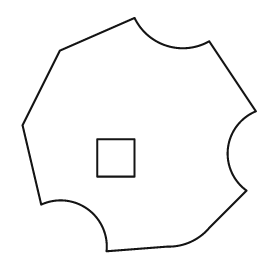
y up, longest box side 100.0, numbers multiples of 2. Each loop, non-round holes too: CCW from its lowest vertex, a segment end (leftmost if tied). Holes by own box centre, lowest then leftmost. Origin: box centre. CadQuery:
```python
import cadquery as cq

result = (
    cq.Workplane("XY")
    .moveTo(-14.0, -50.0)
    .lineTo(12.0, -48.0)
    .threePointArc((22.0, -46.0), (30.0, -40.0))
    .lineTo(46.0, -24.0)
    .threePointArc((38.0, -6.0), (50.0, 10.0))
    .lineTo(30.0, 40.0)
    .threePointArc((12.0, 38.0), (-2.0, 50.0))
    .lineTo(-34.0, 36.0)
    .lineTo(-50.0, 4.0)
    .lineTo(-42.0, -30.0)
    .threePointArc((-22.0, -32.0), (-14.0, -50.0))
    .close()
    .moveTo(-18.0, -18.0)
    .lineTo(-2.0, -18.0)
    .lineTo(-2.0, -2.0)
    .lineTo(-18.0, -2.0)
    .close()
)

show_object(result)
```